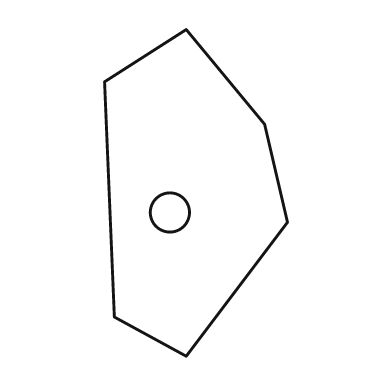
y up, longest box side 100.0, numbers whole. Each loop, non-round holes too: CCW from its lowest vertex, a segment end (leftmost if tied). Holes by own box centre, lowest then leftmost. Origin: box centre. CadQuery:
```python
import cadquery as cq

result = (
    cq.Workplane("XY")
    .moveTo(-3.0, -50.0)
    .lineTo(28.0, -9.0)
    .lineTo(21.0, 21.0)
    .lineTo(-3.0, 50.0)
    .lineTo(-28.0, 34.0)
    .lineTo(-25.0, -38.0)
    .close()
    .moveTo(-8.0, -6.0)
    .circle(6.0)
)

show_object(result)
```